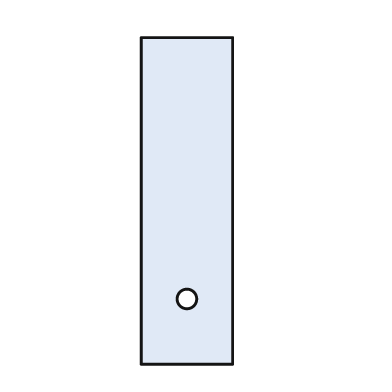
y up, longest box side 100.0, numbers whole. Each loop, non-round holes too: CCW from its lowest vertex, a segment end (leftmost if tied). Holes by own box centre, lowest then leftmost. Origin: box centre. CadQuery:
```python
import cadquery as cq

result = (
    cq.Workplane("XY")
    .moveTo(-14.0, -50.0)
    .lineTo(14.0, -50.0)
    .lineTo(14.0, 50.0)
    .lineTo(-14.0, 50.0)
    .close()
    .moveTo(0.0, -30.0)
    .circle(3.0)
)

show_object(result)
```